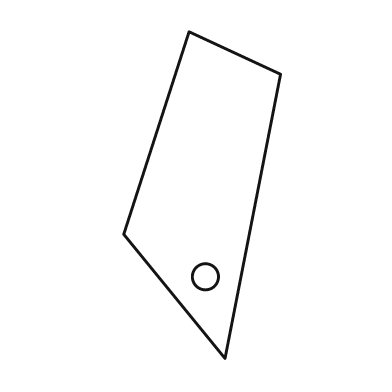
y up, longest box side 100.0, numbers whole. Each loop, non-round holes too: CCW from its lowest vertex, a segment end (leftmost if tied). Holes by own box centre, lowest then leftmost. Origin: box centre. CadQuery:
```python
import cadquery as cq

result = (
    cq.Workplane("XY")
    .moveTo(7.0, -50.0)
    .lineTo(24.0, 37.0)
    .lineTo(-4.0, 50.0)
    .lineTo(-24.0, -12.0)
    .close()
    .moveTo(1.0, -25.0)
    .circle(4.0)
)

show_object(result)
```